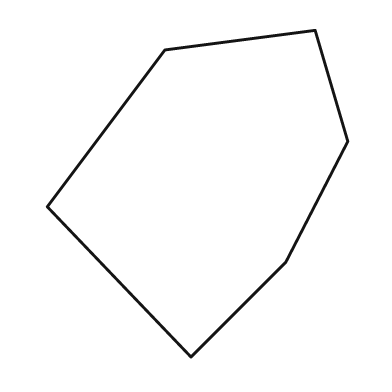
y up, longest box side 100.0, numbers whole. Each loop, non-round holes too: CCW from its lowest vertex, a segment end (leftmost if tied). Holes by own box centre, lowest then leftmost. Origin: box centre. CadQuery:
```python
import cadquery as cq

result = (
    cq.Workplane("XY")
    .moveTo(-2.0, -50.0)
    .lineTo(27.0, -21.0)
    .lineTo(46.0, 16.0)
    .lineTo(36.0, 50.0)
    .lineTo(-10.0, 44.0)
    .lineTo(-46.0, -4.0)
    .close()
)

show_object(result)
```